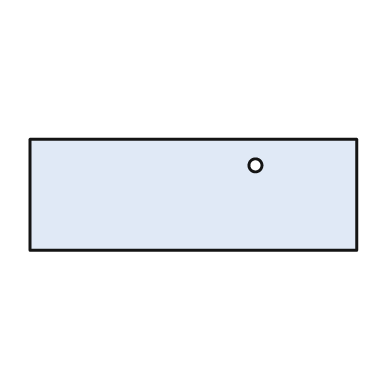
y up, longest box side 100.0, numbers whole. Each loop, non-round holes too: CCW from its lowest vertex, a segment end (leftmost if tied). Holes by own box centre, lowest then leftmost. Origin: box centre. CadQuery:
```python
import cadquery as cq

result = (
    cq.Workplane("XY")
    .moveTo(-50.0, -17.0)
    .lineTo(50.0, -17.0)
    .lineTo(50.0, 17.0)
    .lineTo(-50.0, 17.0)
    .close()
    .moveTo(19.0, 9.0)
    .circle(2.0)
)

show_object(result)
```